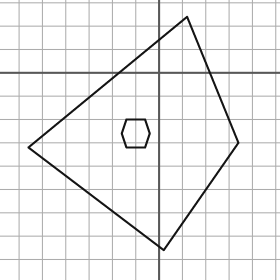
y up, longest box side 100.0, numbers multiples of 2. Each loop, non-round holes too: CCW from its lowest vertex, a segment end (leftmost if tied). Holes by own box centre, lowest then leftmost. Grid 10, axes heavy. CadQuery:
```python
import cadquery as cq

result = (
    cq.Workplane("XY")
    .moveTo(2.0, -76.0)
    .lineTo(34.0, -30.0)
    .lineTo(12.0, 24.0)
    .lineTo(-56.0, -32.0)
    .close()
    .moveTo(-14.0, -32.0)
    .lineTo(-6.0, -32.0)
    .lineTo(-4.0, -26.0)
    .lineTo(-6.0, -20.0)
    .lineTo(-14.0, -20.0)
    .lineTo(-16.0, -26.0)
    .close()
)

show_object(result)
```